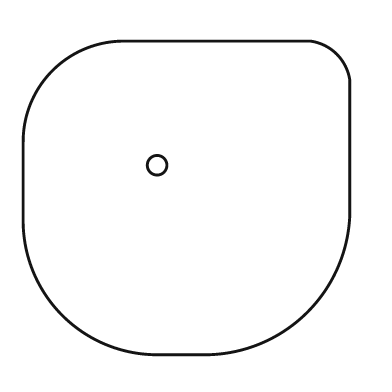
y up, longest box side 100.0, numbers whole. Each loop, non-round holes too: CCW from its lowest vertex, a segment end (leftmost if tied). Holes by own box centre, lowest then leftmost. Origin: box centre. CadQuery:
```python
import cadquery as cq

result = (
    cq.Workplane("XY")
    .moveTo(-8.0, -48.0)
    .lineTo(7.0, -48.0)
    .threePointArc((37.0, -35.0), (50.0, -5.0))
    .lineTo(50.0, 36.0)
    .threePointArc((46.0, 44.0), (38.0, 48.0))
    .lineTo(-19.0, 48.0)
    .threePointArc((-41.0, 39.0), (-50.0, 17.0))
    .lineTo(-50.0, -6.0)
    .threePointArc((-38.0, -36.0), (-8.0, -48.0))
    .close()
    .moveTo(-9.0, 10.0)
    .circle(3.0)
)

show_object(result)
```